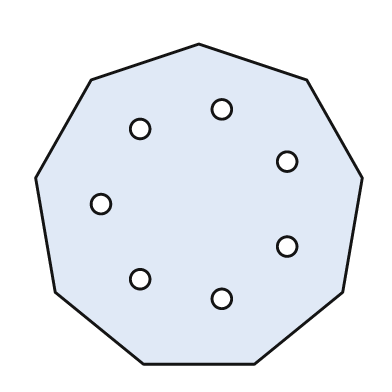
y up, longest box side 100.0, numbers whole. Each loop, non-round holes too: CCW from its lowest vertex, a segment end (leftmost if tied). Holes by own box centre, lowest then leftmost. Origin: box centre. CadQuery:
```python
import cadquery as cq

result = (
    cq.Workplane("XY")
    .moveTo(-17.0, -49.0)
    .lineTo(17.0, -49.0)
    .lineTo(44.0, -27.0)
    .lineTo(50.0, 8.0)
    .lineTo(33.0, 38.0)
    .lineTo(0.0, 49.0)
    .lineTo(-33.0, 38.0)
    .lineTo(-50.0, 8.0)
    .lineTo(-44.0, -27.0)
    .close()
    .moveTo(7.0, -29.0)
    .circle(3.0)
    .moveTo(-18.0, -23.0)
    .circle(3.0)
    .moveTo(27.0, -13.0)
    .circle(3.0)
    .moveTo(-30.0, 0.0)
    .circle(3.0)
    .moveTo(27.0, 13.0)
    .circle(3.0)
    .moveTo(-18.0, 23.0)
    .circle(3.0)
    .moveTo(7.0, 29.0)
    .circle(3.0)
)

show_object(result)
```